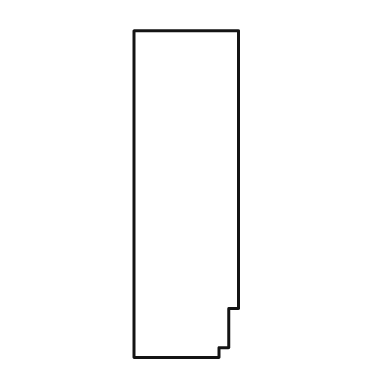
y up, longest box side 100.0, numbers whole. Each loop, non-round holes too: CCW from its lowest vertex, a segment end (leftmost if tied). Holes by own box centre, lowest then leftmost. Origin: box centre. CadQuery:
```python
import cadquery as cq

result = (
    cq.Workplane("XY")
    .moveTo(-16.0, -50.0)
    .lineTo(10.0, -50.0)
    .lineTo(10.0, -47.0)
    .lineTo(13.0, -47.0)
    .lineTo(13.0, -35.0)
    .lineTo(16.0, -35.0)
    .lineTo(16.0, 50.0)
    .lineTo(-16.0, 50.0)
    .close()
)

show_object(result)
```